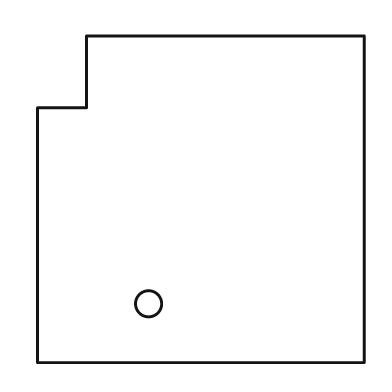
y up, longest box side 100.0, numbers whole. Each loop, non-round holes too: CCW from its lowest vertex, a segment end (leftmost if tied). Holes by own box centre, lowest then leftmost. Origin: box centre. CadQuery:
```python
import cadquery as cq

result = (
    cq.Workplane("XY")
    .moveTo(-50.0, -50.0)
    .lineTo(50.0, -50.0)
    .lineTo(50.0, 50.0)
    .lineTo(-35.0, 50.0)
    .lineTo(-35.0, 28.0)
    .lineTo(-50.0, 28.0)
    .close()
    .moveTo(-16.0, -32.0)
    .circle(4.0)
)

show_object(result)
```